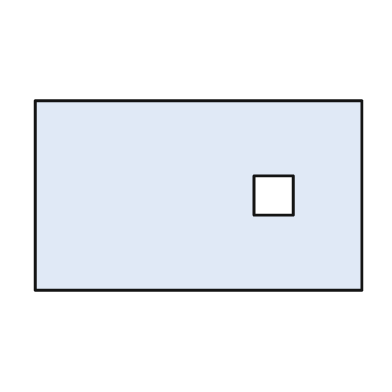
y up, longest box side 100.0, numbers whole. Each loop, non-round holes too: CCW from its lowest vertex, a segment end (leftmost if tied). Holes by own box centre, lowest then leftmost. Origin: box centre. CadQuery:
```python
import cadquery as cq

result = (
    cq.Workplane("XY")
    .moveTo(-50.0, -29.0)
    .lineTo(50.0, -29.0)
    .lineTo(50.0, 29.0)
    .lineTo(-50.0, 29.0)
    .close()
    .moveTo(17.0, -6.0)
    .lineTo(29.0, -6.0)
    .lineTo(29.0, 6.0)
    .lineTo(17.0, 6.0)
    .close()
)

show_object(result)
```